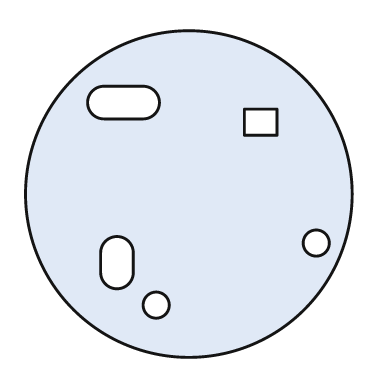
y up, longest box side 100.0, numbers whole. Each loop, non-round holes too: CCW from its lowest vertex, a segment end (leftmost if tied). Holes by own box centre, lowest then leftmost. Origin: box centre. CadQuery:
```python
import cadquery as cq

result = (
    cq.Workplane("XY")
    .moveTo(0.0, 0.0)
    .circle(50.0)
    .moveTo(-10.0, -34.0)
    .circle(4.0)
    .moveTo(-27.0, -24.0)
    .threePointArc((-22.0, -29.0), (-17.0, -24.0))
    .lineTo(-17.0, -18.0)
    .threePointArc((-22.0, -13.0), (-27.0, -18.0))
    .close()
    .moveTo(39.0, -15.0)
    .circle(4.0)
    .moveTo(17.0, 18.0)
    .lineTo(27.0, 18.0)
    .lineTo(27.0, 26.0)
    .lineTo(17.0, 26.0)
    .close()
    .moveTo(-26.0, 23.0)
    .lineTo(-14.0, 23.0)
    .threePointArc((-9.0, 28.0), (-14.0, 33.0))
    .lineTo(-26.0, 33.0)
    .threePointArc((-31.0, 28.0), (-26.0, 23.0))
    .close()
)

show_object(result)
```